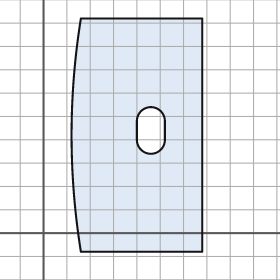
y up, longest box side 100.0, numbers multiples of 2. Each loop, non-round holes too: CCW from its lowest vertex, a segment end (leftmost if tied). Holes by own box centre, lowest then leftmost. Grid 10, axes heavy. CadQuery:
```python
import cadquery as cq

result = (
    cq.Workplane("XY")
    .moveTo(16.0, -8.0)
    .lineTo(68.0, -8.0)
    .lineTo(68.0, 92.0)
    .lineTo(16.0, 92.0)
    .threePointArc((12.0, 42.0), (16.0, -8.0))
    .close()
    .moveTo(40.0, 40.0)
    .threePointArc((46.0, 34.0), (52.0, 40.0))
    .lineTo(52.0, 48.0)
    .threePointArc((46.0, 54.0), (40.0, 48.0))
    .close()
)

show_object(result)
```